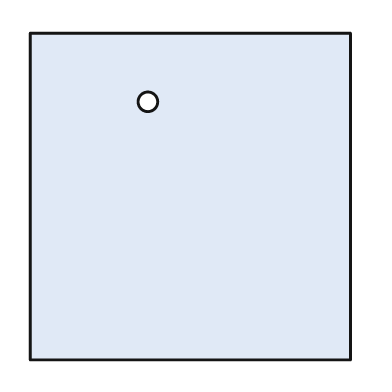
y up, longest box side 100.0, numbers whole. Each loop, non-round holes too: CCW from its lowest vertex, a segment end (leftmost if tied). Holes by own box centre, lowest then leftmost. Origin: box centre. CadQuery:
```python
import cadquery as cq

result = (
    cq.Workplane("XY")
    .moveTo(-49.0, -50.0)
    .lineTo(49.0, -50.0)
    .lineTo(49.0, 50.0)
    .lineTo(-49.0, 50.0)
    .close()
    .moveTo(-13.0, 29.0)
    .circle(3.0)
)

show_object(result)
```